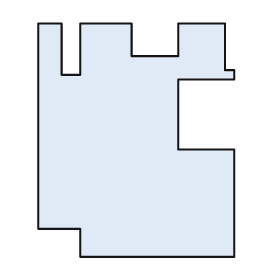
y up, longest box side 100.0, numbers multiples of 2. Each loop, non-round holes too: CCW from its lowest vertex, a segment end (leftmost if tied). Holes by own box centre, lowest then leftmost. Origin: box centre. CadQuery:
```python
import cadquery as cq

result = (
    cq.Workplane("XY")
    .moveTo(-24.0, -50.0)
    .lineTo(42.0, -50.0)
    .lineTo(42.0, -4.0)
    .lineTo(18.0, -4.0)
    .lineTo(18.0, 26.0)
    .lineTo(42.0, 26.0)
    .lineTo(42.0, 30.0)
    .lineTo(38.0, 30.0)
    .lineTo(38.0, 50.0)
    .lineTo(18.0, 50.0)
    .lineTo(18.0, 36.0)
    .lineTo(-2.0, 36.0)
    .lineTo(-2.0, 50.0)
    .lineTo(-24.0, 50.0)
    .lineTo(-24.0, 28.0)
    .lineTo(-32.0, 28.0)
    .lineTo(-32.0, 50.0)
    .lineTo(-42.0, 50.0)
    .lineTo(-42.0, -38.0)
    .lineTo(-24.0, -38.0)
    .close()
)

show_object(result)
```